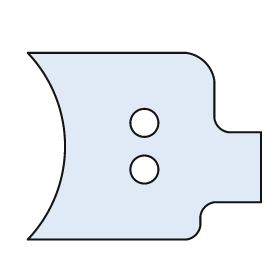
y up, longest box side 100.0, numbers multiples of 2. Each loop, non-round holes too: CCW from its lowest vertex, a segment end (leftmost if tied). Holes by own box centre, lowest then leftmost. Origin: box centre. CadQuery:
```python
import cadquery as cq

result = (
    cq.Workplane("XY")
    .moveTo(-50.0, -40.0)
    .lineTo(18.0, -40.0)
    .threePointArc((22.0, -38.0), (24.0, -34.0))
    .lineTo(24.0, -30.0)
    .threePointArc((26.0, -26.0), (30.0, -24.0))
    .lineTo(50.0, -24.0)
    .lineTo(50.0, 6.0)
    .lineTo(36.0, 6.0)
    .threePointArc((32.0, 8.0), (30.0, 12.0))
    .lineTo(30.0, 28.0)
    .threePointArc((26.0, 36.0), (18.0, 40.0))
    .lineTo(-50.0, 40.0)
    .threePointArc((-34.0, 0.0), (-50.0, -40.0))
    .close()
    .moveTo(0.0, -10.0)
    .circle(6.0)
    .moveTo(0.0, 10.0)
    .circle(6.0)
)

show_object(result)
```